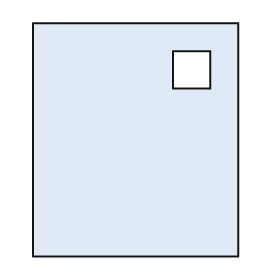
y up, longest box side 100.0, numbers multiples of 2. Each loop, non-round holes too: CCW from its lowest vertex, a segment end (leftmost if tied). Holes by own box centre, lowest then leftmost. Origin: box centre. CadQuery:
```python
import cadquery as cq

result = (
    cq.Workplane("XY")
    .moveTo(-44.0, -50.0)
    .lineTo(44.0, -50.0)
    .lineTo(44.0, 50.0)
    .lineTo(-44.0, 50.0)
    .close()
    .moveTo(16.0, 22.0)
    .lineTo(32.0, 22.0)
    .lineTo(32.0, 38.0)
    .lineTo(16.0, 38.0)
    .close()
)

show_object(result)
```